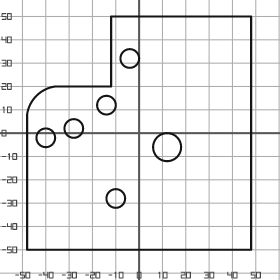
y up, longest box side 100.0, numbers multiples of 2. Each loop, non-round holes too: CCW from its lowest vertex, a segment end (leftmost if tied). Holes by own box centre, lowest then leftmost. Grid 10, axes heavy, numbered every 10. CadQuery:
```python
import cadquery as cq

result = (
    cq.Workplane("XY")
    .moveTo(-48.0, -50.0)
    .lineTo(48.0, -50.0)
    .lineTo(48.0, 50.0)
    .lineTo(-12.0, 50.0)
    .lineTo(-12.0, 20.0)
    .lineTo(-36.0, 20.0)
    .threePointArc((-44.0, 16.0), (-48.0, 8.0))
    .close()
    .moveTo(-10.0, -28.0)
    .circle(4.0)
    .moveTo(12.0, -6.0)
    .circle(6.0)
    .moveTo(-40.0, -2.0)
    .circle(4.0)
    .moveTo(-28.0, 2.0)
    .circle(4.0)
    .moveTo(-14.0, 12.0)
    .circle(4.0)
    .moveTo(-4.0, 32.0)
    .circle(4.0)
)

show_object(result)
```